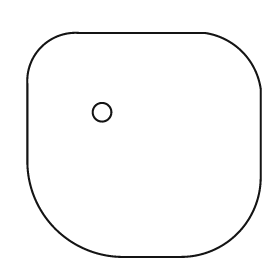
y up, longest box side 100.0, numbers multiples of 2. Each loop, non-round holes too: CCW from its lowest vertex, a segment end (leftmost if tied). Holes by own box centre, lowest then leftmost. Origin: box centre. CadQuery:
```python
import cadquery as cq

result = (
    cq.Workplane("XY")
    .moveTo(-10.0, -48.0)
    .lineTo(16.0, -48.0)
    .threePointArc((40.0, -38.0), (50.0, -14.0))
    .lineTo(50.0, 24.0)
    .threePointArc((42.0, 40.0), (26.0, 48.0))
    .lineTo(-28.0, 48.0)
    .threePointArc((-44.0, 42.0), (-50.0, 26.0))
    .lineTo(-50.0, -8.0)
    .threePointArc((-38.0, -36.0), (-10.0, -48.0))
    .close()
    .moveTo(-18.0, 14.0)
    .circle(4.0)
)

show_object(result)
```